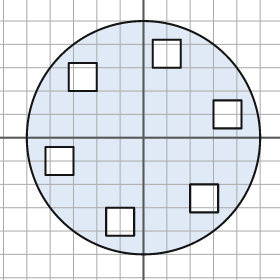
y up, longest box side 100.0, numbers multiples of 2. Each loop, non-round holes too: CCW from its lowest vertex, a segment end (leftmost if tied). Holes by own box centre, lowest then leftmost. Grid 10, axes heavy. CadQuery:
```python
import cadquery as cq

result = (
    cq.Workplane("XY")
    .moveTo(0.0, 0.0)
    .circle(50.0)
    .moveTo(-16.0, -42.0)
    .lineTo(-4.0, -42.0)
    .lineTo(-4.0, -30.0)
    .lineTo(-16.0, -30.0)
    .close()
    .moveTo(20.0, -32.0)
    .lineTo(32.0, -32.0)
    .lineTo(32.0, -20.0)
    .lineTo(20.0, -20.0)
    .close()
    .moveTo(-42.0, -16.0)
    .lineTo(-30.0, -16.0)
    .lineTo(-30.0, -4.0)
    .lineTo(-42.0, -4.0)
    .close()
    .moveTo(30.0, 4.0)
    .lineTo(42.0, 4.0)
    .lineTo(42.0, 16.0)
    .lineTo(30.0, 16.0)
    .close()
    .moveTo(-32.0, 20.0)
    .lineTo(-20.0, 20.0)
    .lineTo(-20.0, 32.0)
    .lineTo(-32.0, 32.0)
    .close()
    .moveTo(4.0, 30.0)
    .lineTo(16.0, 30.0)
    .lineTo(16.0, 42.0)
    .lineTo(4.0, 42.0)
    .close()
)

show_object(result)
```